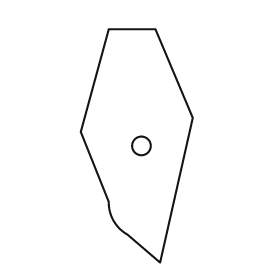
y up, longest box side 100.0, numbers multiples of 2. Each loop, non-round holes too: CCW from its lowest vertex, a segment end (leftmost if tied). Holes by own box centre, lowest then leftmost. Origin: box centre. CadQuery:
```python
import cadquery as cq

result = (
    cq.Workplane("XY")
    .moveTo(10.0, -50.0)
    .lineTo(24.0, 12.0)
    .lineTo(8.0, 50.0)
    .lineTo(-12.0, 50.0)
    .lineTo(-24.0, 6.0)
    .lineTo(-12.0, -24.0)
    .threePointArc((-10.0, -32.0), (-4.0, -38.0))
    .close()
    .moveTo(2.0, 0.0)
    .circle(4.0)
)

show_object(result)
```